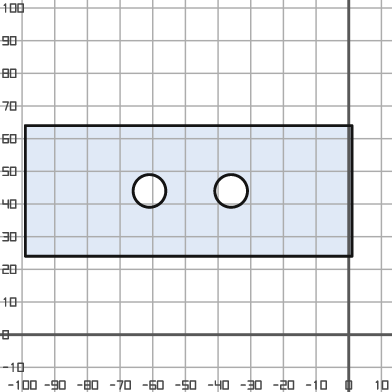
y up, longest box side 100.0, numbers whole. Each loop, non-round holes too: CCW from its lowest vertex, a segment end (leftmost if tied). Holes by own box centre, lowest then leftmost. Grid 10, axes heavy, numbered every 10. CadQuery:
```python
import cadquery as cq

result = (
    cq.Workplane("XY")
    .moveTo(-99.0, 24.0)
    .lineTo(1.0, 24.0)
    .lineTo(1.0, 64.0)
    .lineTo(-99.0, 64.0)
    .close()
    .moveTo(-61.0, 44.0)
    .circle(5.0)
    .moveTo(-36.0, 44.0)
    .circle(5.0)
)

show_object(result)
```